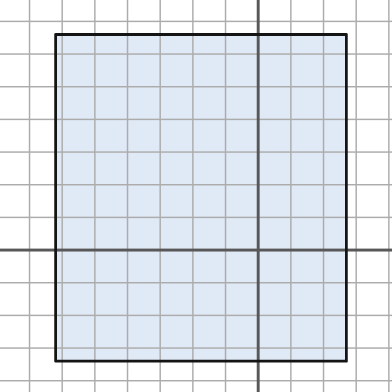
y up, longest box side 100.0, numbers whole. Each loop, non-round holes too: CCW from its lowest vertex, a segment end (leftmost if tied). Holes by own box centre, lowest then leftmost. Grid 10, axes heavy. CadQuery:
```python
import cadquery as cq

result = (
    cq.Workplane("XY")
    .moveTo(-62.0, -34.0)
    .lineTo(27.0, -34.0)
    .lineTo(27.0, 66.0)
    .lineTo(-62.0, 66.0)
    .close()
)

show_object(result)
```